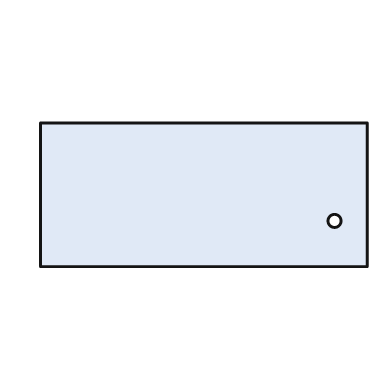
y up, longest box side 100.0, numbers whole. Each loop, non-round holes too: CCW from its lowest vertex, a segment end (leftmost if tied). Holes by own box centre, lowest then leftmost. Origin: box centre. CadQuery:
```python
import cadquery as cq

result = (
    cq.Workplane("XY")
    .moveTo(-50.0, -22.0)
    .lineTo(50.0, -22.0)
    .lineTo(50.0, 22.0)
    .lineTo(-50.0, 22.0)
    .close()
    .moveTo(40.0, -8.0)
    .circle(2.0)
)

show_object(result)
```